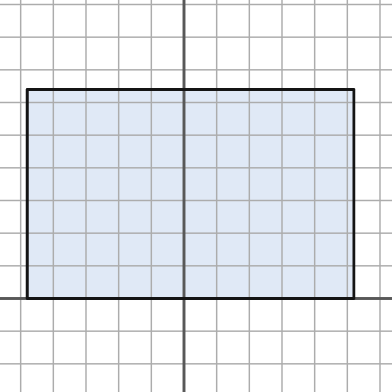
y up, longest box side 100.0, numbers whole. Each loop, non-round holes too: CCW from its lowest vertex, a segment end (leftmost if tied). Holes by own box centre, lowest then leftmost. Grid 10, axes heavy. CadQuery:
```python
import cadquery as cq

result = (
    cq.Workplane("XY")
    .moveTo(-48.0, 0.0)
    .lineTo(52.0, 0.0)
    .lineTo(52.0, 64.0)
    .lineTo(-48.0, 64.0)
    .close()
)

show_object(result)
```